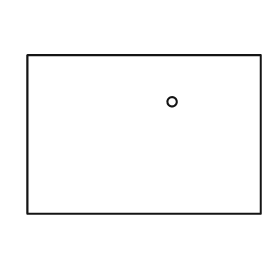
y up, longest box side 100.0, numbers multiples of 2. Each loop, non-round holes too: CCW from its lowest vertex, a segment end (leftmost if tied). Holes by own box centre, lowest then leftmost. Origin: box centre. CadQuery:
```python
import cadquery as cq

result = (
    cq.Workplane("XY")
    .moveTo(-50.0, -34.0)
    .lineTo(50.0, -34.0)
    .lineTo(50.0, 34.0)
    .lineTo(-50.0, 34.0)
    .close()
    .moveTo(12.0, 14.0)
    .circle(2.0)
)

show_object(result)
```